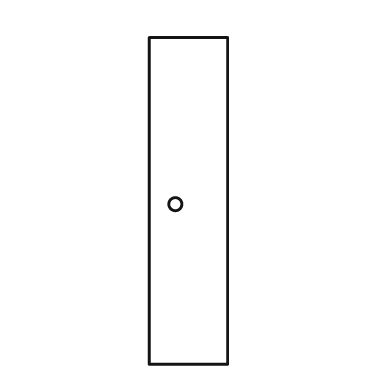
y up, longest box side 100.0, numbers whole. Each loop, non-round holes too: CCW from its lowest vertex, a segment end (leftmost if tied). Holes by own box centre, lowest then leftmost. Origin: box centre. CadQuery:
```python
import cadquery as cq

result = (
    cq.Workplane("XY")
    .moveTo(-12.0, -50.0)
    .lineTo(12.0, -50.0)
    .lineTo(12.0, 50.0)
    .lineTo(-12.0, 50.0)
    .close()
    .moveTo(-4.0, -1.0)
    .circle(2.0)
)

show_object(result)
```